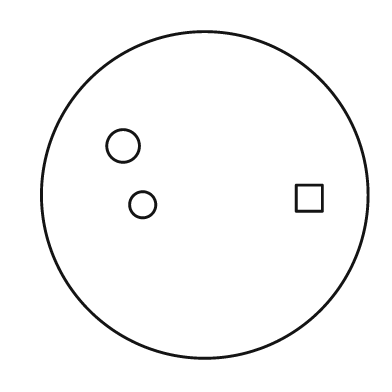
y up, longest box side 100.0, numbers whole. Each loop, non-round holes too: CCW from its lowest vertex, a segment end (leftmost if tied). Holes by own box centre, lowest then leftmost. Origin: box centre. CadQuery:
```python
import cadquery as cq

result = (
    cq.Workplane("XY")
    .moveTo(0.0, 0.0)
    .circle(50.0)
    .moveTo(-19.0, -3.0)
    .circle(4.0)
    .moveTo(28.0, -5.0)
    .lineTo(36.0, -5.0)
    .lineTo(36.0, 3.0)
    .lineTo(28.0, 3.0)
    .close()
    .moveTo(-25.0, 15.0)
    .circle(5.0)
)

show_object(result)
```